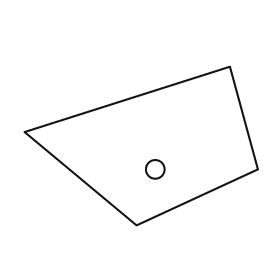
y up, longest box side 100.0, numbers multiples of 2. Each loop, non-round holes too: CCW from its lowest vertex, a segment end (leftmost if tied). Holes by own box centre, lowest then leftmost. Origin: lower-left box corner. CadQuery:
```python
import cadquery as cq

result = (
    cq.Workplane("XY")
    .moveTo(48.0, 0.0)
    .lineTo(100.0, 24.0)
    .lineTo(88.0, 68.0)
    .lineTo(0.0, 40.0)
    .close()
    .moveTo(56.0, 24.0)
    .circle(4.0)
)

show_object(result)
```